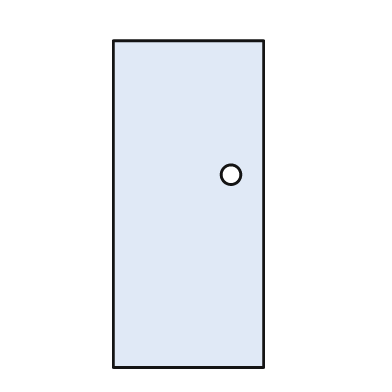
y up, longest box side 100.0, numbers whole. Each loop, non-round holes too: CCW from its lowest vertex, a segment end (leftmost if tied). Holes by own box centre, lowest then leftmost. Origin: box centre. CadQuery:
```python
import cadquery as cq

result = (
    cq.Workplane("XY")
    .moveTo(-23.0, -50.0)
    .lineTo(23.0, -50.0)
    .lineTo(23.0, 50.0)
    .lineTo(-23.0, 50.0)
    .close()
    .moveTo(13.0, 9.0)
    .circle(3.0)
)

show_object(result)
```